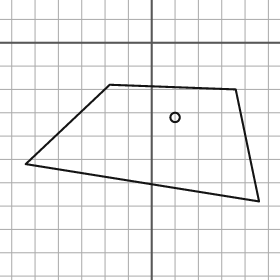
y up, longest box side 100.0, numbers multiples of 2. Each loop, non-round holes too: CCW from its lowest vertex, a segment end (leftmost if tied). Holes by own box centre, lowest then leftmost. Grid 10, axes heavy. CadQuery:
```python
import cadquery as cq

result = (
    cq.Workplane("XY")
    .moveTo(46.0, -68.0)
    .lineTo(36.0, -20.0)
    .lineTo(-18.0, -18.0)
    .lineTo(-54.0, -52.0)
    .close()
    .moveTo(10.0, -32.0)
    .circle(2.0)
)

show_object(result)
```